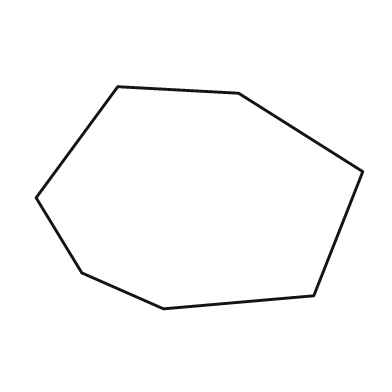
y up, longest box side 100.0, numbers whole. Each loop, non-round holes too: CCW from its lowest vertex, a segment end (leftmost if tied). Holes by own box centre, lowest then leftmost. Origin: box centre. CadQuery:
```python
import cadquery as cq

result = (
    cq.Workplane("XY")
    .moveTo(-11.0, -34.0)
    .lineTo(35.0, -30.0)
    .lineTo(50.0, 8.0)
    .lineTo(12.0, 32.0)
    .lineTo(-25.0, 34.0)
    .lineTo(-50.0, 0.0)
    .lineTo(-36.0, -23.0)
    .close()
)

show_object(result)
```